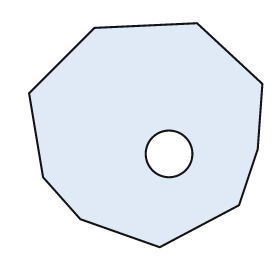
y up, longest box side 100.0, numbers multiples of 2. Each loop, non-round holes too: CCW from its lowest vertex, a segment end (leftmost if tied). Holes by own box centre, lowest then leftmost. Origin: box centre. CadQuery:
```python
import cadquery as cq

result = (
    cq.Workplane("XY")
    .moveTo(6.0, -48.0)
    .lineTo(40.0, -30.0)
    .lineTo(48.0, -6.0)
    .lineTo(50.0, 22.0)
    .lineTo(22.0, 48.0)
    .lineTo(-22.0, 46.0)
    .lineTo(-50.0, 18.0)
    .lineTo(-44.0, -18.0)
    .lineTo(-28.0, -36.0)
    .close()
    .moveTo(10.0, -8.0)
    .circle(10.0)
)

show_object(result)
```